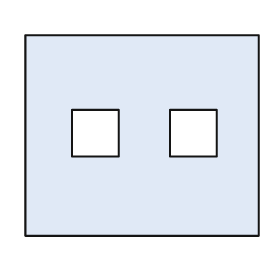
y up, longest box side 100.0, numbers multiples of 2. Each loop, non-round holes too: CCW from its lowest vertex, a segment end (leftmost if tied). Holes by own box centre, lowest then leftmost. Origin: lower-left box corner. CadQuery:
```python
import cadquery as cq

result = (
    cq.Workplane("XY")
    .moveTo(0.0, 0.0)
    .lineTo(100.0, 0.0)
    .lineTo(100.0, 86.0)
    .lineTo(0.0, 86.0)
    .close()
    .moveTo(20.0, 34.0)
    .lineTo(40.0, 34.0)
    .lineTo(40.0, 54.0)
    .lineTo(20.0, 54.0)
    .close()
    .moveTo(62.0, 34.0)
    .lineTo(82.0, 34.0)
    .lineTo(82.0, 54.0)
    .lineTo(62.0, 54.0)
    .close()
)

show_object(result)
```